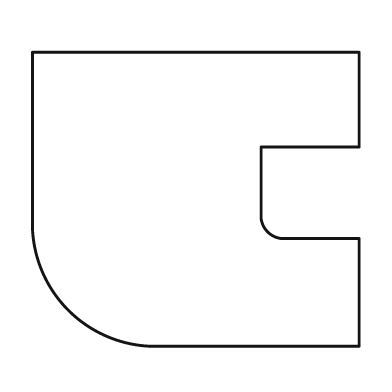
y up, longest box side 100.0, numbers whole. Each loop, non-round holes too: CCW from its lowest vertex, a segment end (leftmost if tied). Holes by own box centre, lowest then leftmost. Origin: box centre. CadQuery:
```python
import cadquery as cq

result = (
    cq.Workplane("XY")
    .moveTo(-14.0, -45.0)
    .lineTo(50.0, -45.0)
    .lineTo(50.0, -12.0)
    .lineTo(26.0, -12.0)
    .threePointArc((22.0, -10.0), (20.0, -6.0))
    .lineTo(20.0, 16.0)
    .lineTo(50.0, 16.0)
    .lineTo(50.0, 45.0)
    .lineTo(-50.0, 45.0)
    .lineTo(-50.0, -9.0)
    .threePointArc((-39.0, -34.0), (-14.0, -45.0))
    .close()
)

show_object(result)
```